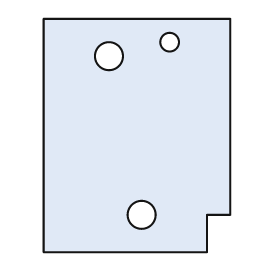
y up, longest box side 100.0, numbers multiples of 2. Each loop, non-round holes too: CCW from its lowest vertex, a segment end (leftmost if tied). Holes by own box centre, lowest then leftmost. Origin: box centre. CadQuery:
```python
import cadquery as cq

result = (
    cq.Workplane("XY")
    .moveTo(-40.0, -50.0)
    .lineTo(30.0, -50.0)
    .lineTo(30.0, -34.0)
    .lineTo(40.0, -34.0)
    .lineTo(40.0, 50.0)
    .lineTo(-40.0, 50.0)
    .close()
    .moveTo(2.0, -34.0)
    .circle(6.0)
    .moveTo(-12.0, 34.0)
    .circle(6.0)
    .moveTo(14.0, 40.0)
    .circle(4.0)
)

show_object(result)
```